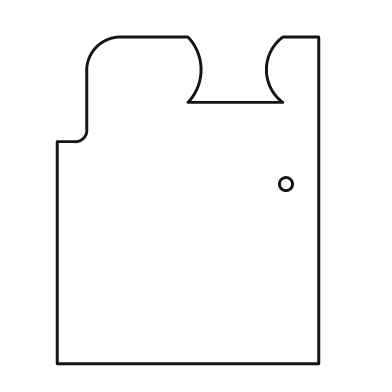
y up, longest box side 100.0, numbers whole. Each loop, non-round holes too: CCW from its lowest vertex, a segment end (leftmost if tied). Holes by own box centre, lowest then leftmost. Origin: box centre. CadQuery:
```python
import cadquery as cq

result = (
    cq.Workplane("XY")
    .moveTo(-40.0, -50.0)
    .lineTo(40.0, -50.0)
    .lineTo(40.0, 50.0)
    .lineTo(29.0, 50.0)
    .threePointArc((24.0, 40.0), (29.0, 30.0))
    .lineTo(0.0, 30.0)
    .threePointArc((4.0, 40.0), (0.0, 50.0))
    .lineTo(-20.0, 50.0)
    .threePointArc((-28.0, 47.0), (-31.0, 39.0))
    .lineTo(-31.0, 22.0)
    .threePointArc((-32.0, 19.0), (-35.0, 18.0))
    .lineTo(-40.0, 18.0)
    .close()
    .moveTo(30.0, 5.0)
    .circle(2.0)
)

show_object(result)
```